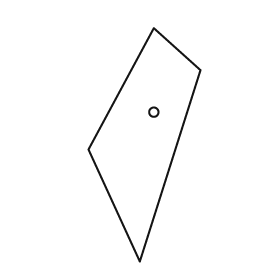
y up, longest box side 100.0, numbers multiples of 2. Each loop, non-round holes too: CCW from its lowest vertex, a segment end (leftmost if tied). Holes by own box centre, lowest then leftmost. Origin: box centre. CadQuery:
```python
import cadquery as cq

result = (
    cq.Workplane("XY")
    .moveTo(-2.0, -50.0)
    .lineTo(24.0, 32.0)
    .lineTo(4.0, 50.0)
    .lineTo(-24.0, -2.0)
    .close()
    .moveTo(4.0, 14.0)
    .circle(2.0)
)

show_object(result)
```